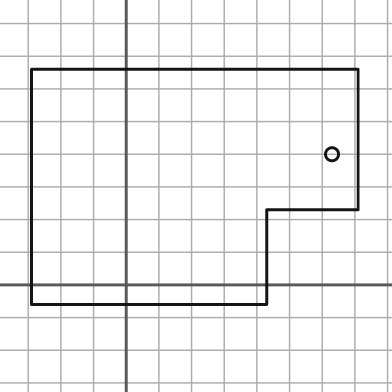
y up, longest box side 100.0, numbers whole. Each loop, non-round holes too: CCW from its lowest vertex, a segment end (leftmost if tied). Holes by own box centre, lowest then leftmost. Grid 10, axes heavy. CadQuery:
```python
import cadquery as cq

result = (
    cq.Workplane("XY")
    .moveTo(-29.0, -6.0)
    .lineTo(43.0, -6.0)
    .lineTo(43.0, 23.0)
    .lineTo(71.0, 23.0)
    .lineTo(71.0, 66.0)
    .lineTo(-29.0, 66.0)
    .close()
    .moveTo(63.0, 40.0)
    .circle(2.0)
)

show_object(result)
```